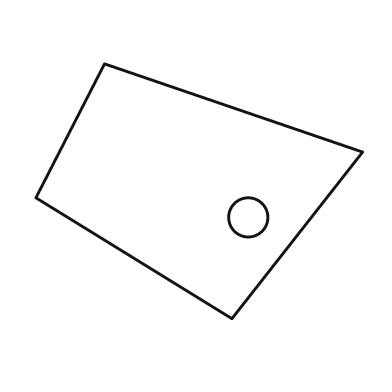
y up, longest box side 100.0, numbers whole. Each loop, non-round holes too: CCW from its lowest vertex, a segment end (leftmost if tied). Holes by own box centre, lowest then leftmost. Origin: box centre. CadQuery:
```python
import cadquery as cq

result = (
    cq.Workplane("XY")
    .moveTo(10.0, -39.0)
    .lineTo(50.0, 12.0)
    .lineTo(-29.0, 39.0)
    .lineTo(-50.0, -2.0)
    .close()
    .moveTo(15.0, -8.0)
    .circle(6.0)
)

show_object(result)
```